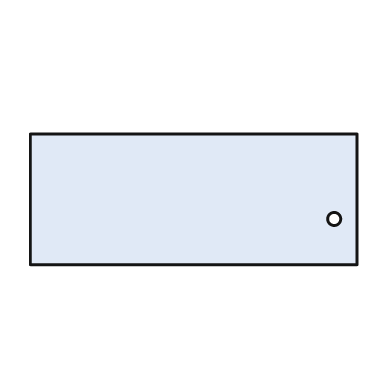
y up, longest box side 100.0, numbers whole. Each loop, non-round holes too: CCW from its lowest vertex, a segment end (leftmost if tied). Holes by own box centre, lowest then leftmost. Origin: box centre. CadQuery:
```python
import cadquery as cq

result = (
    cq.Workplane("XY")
    .moveTo(-50.0, -20.0)
    .lineTo(50.0, -20.0)
    .lineTo(50.0, 20.0)
    .lineTo(-50.0, 20.0)
    .close()
    .moveTo(43.0, -6.0)
    .circle(2.0)
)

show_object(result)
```